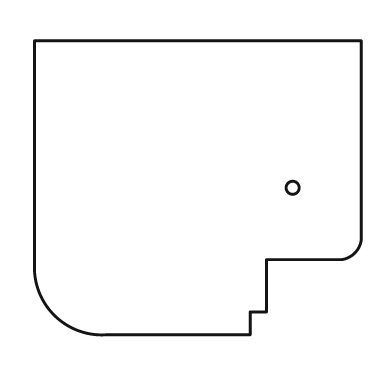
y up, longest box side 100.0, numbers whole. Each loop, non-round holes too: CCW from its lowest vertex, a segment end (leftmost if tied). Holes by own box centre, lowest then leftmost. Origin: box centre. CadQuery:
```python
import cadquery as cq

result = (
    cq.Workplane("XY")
    .moveTo(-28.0, -45.0)
    .lineTo(16.0, -45.0)
    .lineTo(16.0, -38.0)
    .lineTo(21.0, -38.0)
    .lineTo(21.0, -22.0)
    .lineTo(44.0, -22.0)
    .threePointArc((48.0, -20.0), (50.0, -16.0))
    .lineTo(50.0, 45.0)
    .lineTo(-50.0, 45.0)
    .lineTo(-50.0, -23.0)
    .threePointArc((-44.0, -39.0), (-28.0, -45.0))
    .close()
    .moveTo(29.0, 0.0)
    .circle(2.0)
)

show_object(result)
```